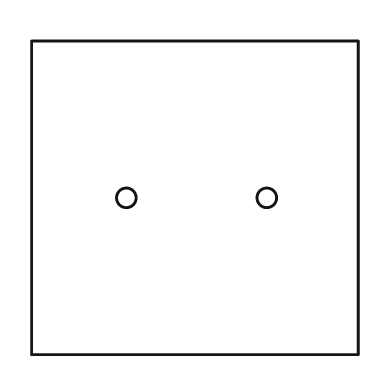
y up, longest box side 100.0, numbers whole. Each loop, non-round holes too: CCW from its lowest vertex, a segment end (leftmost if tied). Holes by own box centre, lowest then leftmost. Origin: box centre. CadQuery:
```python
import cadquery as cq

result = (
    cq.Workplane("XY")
    .moveTo(-50.0, -48.0)
    .lineTo(50.0, -48.0)
    .lineTo(50.0, 48.0)
    .lineTo(-50.0, 48.0)
    .close()
    .moveTo(-21.0, 0.0)
    .circle(3.0)
    .moveTo(22.0, 0.0)
    .circle(3.0)
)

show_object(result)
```